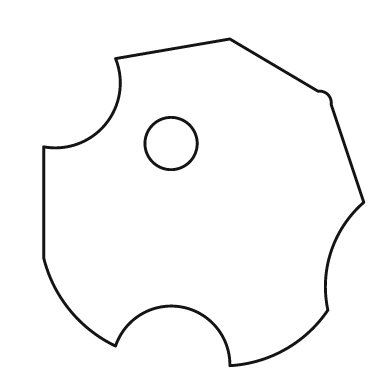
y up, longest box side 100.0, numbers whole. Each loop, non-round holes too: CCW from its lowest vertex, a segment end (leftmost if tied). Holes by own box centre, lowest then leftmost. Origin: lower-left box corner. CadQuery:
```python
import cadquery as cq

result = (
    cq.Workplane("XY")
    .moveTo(57.0, 0.0)
    .threePointArc((74.0, 5.0), (87.0, 17.0))
    .threePointArc((88.0, 35.0), (98.0, 50.0))
    .lineTo(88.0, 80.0)
    .threePointArc((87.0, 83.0), (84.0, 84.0))
    .lineTo(57.0, 100.0)
    .lineTo(22.0, 94.0)
    .threePointArc((19.0, 74.0), (0.0, 67.0))
    .lineTo(0.0, 33.0)
    .threePointArc((8.0, 17.0), (22.0, 6.0))
    .threePointArc((42.0, 18.0), (57.0, 0.0))
    .close()
    .moveTo(39.0, 68.0)
    .circle(8.0)
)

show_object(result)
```